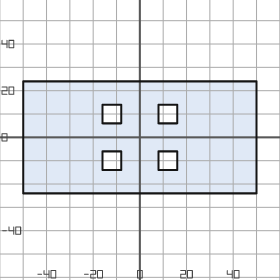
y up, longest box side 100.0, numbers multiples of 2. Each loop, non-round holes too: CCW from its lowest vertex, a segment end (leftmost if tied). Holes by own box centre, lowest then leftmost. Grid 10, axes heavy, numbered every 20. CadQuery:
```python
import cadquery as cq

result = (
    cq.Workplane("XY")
    .moveTo(-50.0, -24.0)
    .lineTo(50.0, -24.0)
    .lineTo(50.0, 24.0)
    .lineTo(-50.0, 24.0)
    .close()
    .moveTo(-16.0, -14.0)
    .lineTo(-8.0, -14.0)
    .lineTo(-8.0, -6.0)
    .lineTo(-16.0, -6.0)
    .close()
    .moveTo(8.0, -14.0)
    .lineTo(16.0, -14.0)
    .lineTo(16.0, -6.0)
    .lineTo(8.0, -6.0)
    .close()
    .moveTo(-16.0, 6.0)
    .lineTo(-8.0, 6.0)
    .lineTo(-8.0, 14.0)
    .lineTo(-16.0, 14.0)
    .close()
    .moveTo(8.0, 6.0)
    .lineTo(16.0, 6.0)
    .lineTo(16.0, 14.0)
    .lineTo(8.0, 14.0)
    .close()
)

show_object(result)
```